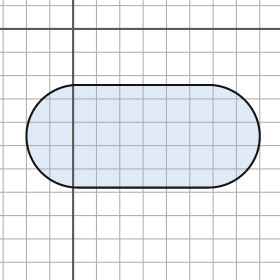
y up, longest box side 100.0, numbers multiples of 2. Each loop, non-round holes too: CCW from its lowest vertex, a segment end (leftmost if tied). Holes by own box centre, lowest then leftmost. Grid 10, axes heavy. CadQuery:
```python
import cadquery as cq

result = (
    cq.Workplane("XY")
    .moveTo(2.0, -68.0)
    .lineTo(58.0, -68.0)
    .threePointArc((80.0, -46.0), (58.0, -24.0))
    .lineTo(2.0, -24.0)
    .threePointArc((-20.0, -46.0), (2.0, -68.0))
    .close()
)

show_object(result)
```